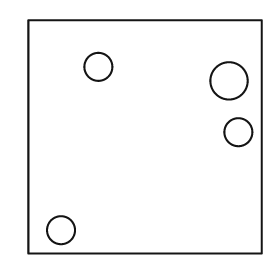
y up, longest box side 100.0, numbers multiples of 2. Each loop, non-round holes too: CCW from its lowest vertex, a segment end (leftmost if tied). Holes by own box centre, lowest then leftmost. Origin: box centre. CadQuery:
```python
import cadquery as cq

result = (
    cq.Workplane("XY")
    .moveTo(-50.0, -50.0)
    .lineTo(50.0, -50.0)
    .lineTo(50.0, 50.0)
    .lineTo(-50.0, 50.0)
    .close()
    .moveTo(-36.0, -40.0)
    .circle(6.0)
    .moveTo(40.0, 2.0)
    .circle(6.0)
    .moveTo(36.0, 24.0)
    .circle(8.0)
    .moveTo(-20.0, 30.0)
    .circle(6.0)
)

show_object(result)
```